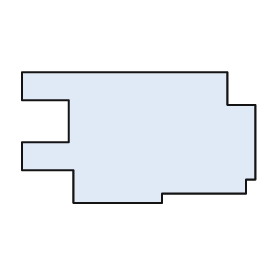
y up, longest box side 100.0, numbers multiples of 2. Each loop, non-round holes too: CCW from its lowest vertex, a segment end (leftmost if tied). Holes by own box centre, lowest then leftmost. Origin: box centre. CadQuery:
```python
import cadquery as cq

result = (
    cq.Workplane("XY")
    .moveTo(-28.0, -28.0)
    .lineTo(10.0, -28.0)
    .lineTo(10.0, -24.0)
    .lineTo(46.0, -24.0)
    .lineTo(46.0, -18.0)
    .lineTo(50.0, -18.0)
    .lineTo(50.0, 14.0)
    .lineTo(38.0, 14.0)
    .lineTo(38.0, 28.0)
    .lineTo(-50.0, 28.0)
    .lineTo(-50.0, 16.0)
    .lineTo(-30.0, 16.0)
    .lineTo(-30.0, -2.0)
    .lineTo(-50.0, -2.0)
    .lineTo(-50.0, -14.0)
    .lineTo(-28.0, -14.0)
    .close()
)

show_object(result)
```